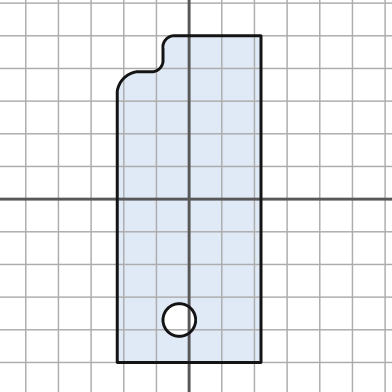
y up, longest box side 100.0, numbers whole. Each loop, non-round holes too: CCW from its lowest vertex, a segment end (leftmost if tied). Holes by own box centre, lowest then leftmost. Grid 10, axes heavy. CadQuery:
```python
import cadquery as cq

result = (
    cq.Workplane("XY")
    .moveTo(-22.0, -50.0)
    .lineTo(22.0, -50.0)
    .lineTo(22.0, 50.0)
    .lineTo(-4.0, 50.0)
    .threePointArc((-7.0, 49.0), (-8.0, 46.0))
    .lineTo(-8.0, 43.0)
    .threePointArc((-9.0, 40.0), (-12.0, 39.0))
    .lineTo(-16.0, 39.0)
    .threePointArc((-20.0, 37.0), (-22.0, 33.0))
    .close()
    .moveTo(-3.0, -37.0)
    .circle(5.0)
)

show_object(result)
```